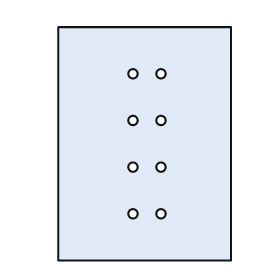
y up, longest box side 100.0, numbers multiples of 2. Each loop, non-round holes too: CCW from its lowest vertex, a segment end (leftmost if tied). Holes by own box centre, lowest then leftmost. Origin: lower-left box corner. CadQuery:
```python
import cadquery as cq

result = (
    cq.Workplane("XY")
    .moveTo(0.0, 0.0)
    .lineTo(74.0, 0.0)
    .lineTo(74.0, 100.0)
    .lineTo(0.0, 100.0)
    .close()
    .moveTo(32.0, 20.0)
    .circle(2.0)
    .moveTo(44.0, 20.0)
    .circle(2.0)
    .moveTo(32.0, 40.0)
    .circle(2.0)
    .moveTo(44.0, 40.0)
    .circle(2.0)
    .moveTo(32.0, 60.0)
    .circle(2.0)
    .moveTo(44.0, 60.0)
    .circle(2.0)
    .moveTo(32.0, 80.0)
    .circle(2.0)
    .moveTo(44.0, 80.0)
    .circle(2.0)
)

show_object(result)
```